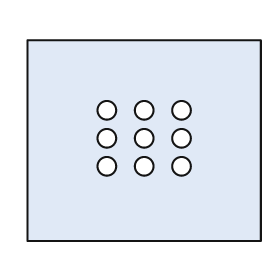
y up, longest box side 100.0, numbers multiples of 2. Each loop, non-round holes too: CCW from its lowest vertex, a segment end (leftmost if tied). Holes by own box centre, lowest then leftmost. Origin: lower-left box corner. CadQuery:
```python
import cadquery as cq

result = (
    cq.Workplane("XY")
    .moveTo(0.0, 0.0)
    .lineTo(100.0, 0.0)
    .lineTo(100.0, 86.0)
    .lineTo(0.0, 86.0)
    .close()
    .moveTo(34.0, 32.0)
    .circle(4.0)
    .moveTo(50.0, 32.0)
    .circle(4.0)
    .moveTo(66.0, 32.0)
    .circle(4.0)
    .moveTo(34.0, 44.0)
    .circle(4.0)
    .moveTo(50.0, 44.0)
    .circle(4.0)
    .moveTo(66.0, 44.0)
    .circle(4.0)
    .moveTo(34.0, 56.0)
    .circle(4.0)
    .moveTo(50.0, 56.0)
    .circle(4.0)
    .moveTo(66.0, 56.0)
    .circle(4.0)
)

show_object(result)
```